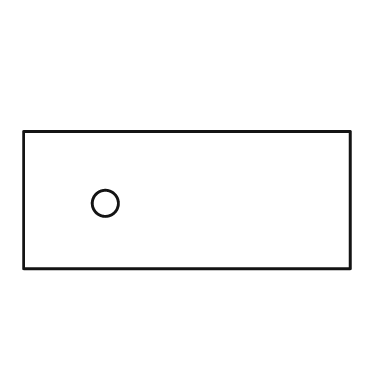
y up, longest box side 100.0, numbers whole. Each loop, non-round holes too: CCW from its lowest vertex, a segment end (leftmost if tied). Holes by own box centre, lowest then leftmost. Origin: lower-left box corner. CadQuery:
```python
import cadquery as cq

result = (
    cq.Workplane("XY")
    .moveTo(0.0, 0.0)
    .lineTo(100.0, 0.0)
    .lineTo(100.0, 42.0)
    .lineTo(0.0, 42.0)
    .close()
    .moveTo(25.0, 20.0)
    .circle(4.0)
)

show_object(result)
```